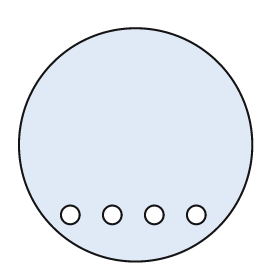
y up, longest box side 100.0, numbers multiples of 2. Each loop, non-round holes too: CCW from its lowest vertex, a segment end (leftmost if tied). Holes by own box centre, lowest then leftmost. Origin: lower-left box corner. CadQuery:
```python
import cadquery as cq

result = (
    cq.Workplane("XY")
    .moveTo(50.0, 50.0)
    .circle(50.0)
    .moveTo(22.0, 20.0)
    .circle(4.0)
    .moveTo(40.0, 20.0)
    .circle(4.0)
    .moveTo(58.0, 20.0)
    .circle(4.0)
    .moveTo(76.0, 20.0)
    .circle(4.0)
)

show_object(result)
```